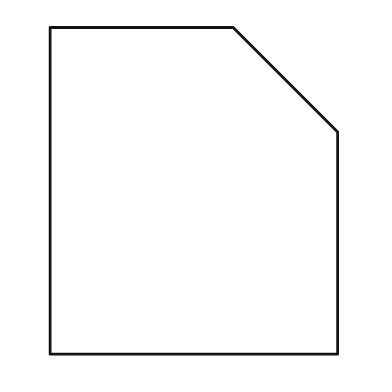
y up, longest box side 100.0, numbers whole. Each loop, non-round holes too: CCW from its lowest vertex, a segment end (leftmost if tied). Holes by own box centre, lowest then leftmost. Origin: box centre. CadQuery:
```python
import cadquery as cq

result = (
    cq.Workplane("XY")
    .moveTo(-44.0, -50.0)
    .lineTo(44.0, -50.0)
    .lineTo(44.0, 18.0)
    .lineTo(12.0, 50.0)
    .lineTo(-44.0, 50.0)
    .close()
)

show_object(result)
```